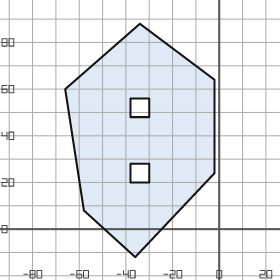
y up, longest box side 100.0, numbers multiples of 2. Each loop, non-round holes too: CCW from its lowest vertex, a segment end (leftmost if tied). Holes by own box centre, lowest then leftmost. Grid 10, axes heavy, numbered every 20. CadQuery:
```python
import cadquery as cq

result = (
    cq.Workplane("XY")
    .moveTo(-36.0, -12.0)
    .lineTo(-2.0, 24.0)
    .lineTo(-2.0, 64.0)
    .lineTo(-34.0, 88.0)
    .lineTo(-66.0, 60.0)
    .lineTo(-58.0, 8.0)
    .close()
    .moveTo(-38.0, 20.0)
    .lineTo(-30.0, 20.0)
    .lineTo(-30.0, 28.0)
    .lineTo(-38.0, 28.0)
    .close()
    .moveTo(-38.0, 48.0)
    .lineTo(-30.0, 48.0)
    .lineTo(-30.0, 56.0)
    .lineTo(-38.0, 56.0)
    .close()
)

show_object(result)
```